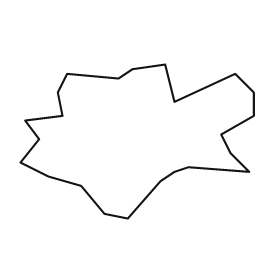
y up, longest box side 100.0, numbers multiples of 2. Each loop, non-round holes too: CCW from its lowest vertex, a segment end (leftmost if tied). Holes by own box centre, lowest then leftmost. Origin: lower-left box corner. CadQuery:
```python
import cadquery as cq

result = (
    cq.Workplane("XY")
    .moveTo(46.0, 0.0)
    .lineTo(60.0, 16.0)
    .lineTo(66.0, 20.0)
    .lineTo(72.0, 22.0)
    .lineTo(98.0, 20.0)
    .lineTo(90.0, 28.0)
    .lineTo(86.0, 36.0)
    .lineTo(100.0, 44.0)
    .lineTo(100.0, 54.0)
    .lineTo(92.0, 62.0)
    .lineTo(66.0, 50.0)
    .lineTo(62.0, 66.0)
    .lineTo(48.0, 64.0)
    .lineTo(42.0, 60.0)
    .lineTo(20.0, 62.0)
    .lineTo(16.0, 54.0)
    .lineTo(18.0, 44.0)
    .lineTo(2.0, 42.0)
    .lineTo(8.0, 34.0)
    .lineTo(0.0, 24.0)
    .lineTo(12.0, 18.0)
    .lineTo(26.0, 14.0)
    .lineTo(36.0, 2.0)
    .close()
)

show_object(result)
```